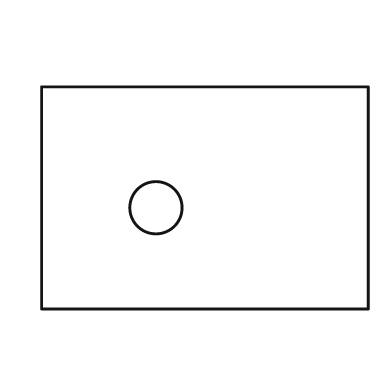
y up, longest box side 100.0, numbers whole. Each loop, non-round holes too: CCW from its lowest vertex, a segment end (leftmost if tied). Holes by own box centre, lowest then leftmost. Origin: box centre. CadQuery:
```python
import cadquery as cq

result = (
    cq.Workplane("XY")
    .moveTo(-50.0, -34.0)
    .lineTo(50.0, -34.0)
    .lineTo(50.0, 34.0)
    .lineTo(-50.0, 34.0)
    .close()
    .moveTo(-15.0, -3.0)
    .circle(8.0)
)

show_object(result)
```